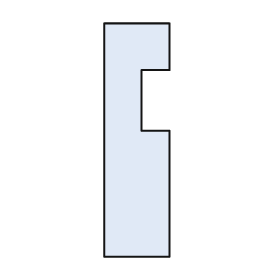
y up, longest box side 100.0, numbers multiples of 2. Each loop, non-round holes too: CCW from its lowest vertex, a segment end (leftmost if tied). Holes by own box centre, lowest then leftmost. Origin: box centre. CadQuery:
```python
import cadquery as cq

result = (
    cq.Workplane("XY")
    .moveTo(-14.0, -50.0)
    .lineTo(14.0, -50.0)
    .lineTo(14.0, 4.0)
    .lineTo(2.0, 4.0)
    .lineTo(2.0, 30.0)
    .lineTo(14.0, 30.0)
    .lineTo(14.0, 50.0)
    .lineTo(-14.0, 50.0)
    .close()
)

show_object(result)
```